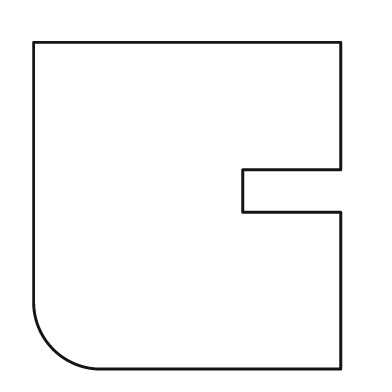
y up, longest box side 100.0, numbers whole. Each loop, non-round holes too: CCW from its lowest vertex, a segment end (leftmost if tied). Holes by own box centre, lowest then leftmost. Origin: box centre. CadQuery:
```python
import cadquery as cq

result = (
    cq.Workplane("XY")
    .moveTo(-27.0, -50.0)
    .lineTo(47.0, -50.0)
    .lineTo(47.0, -2.0)
    .lineTo(17.0, -2.0)
    .lineTo(17.0, 11.0)
    .lineTo(47.0, 11.0)
    .lineTo(47.0, 50.0)
    .lineTo(-47.0, 50.0)
    .lineTo(-47.0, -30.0)
    .threePointArc((-41.0, -44.0), (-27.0, -50.0))
    .close()
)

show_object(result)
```